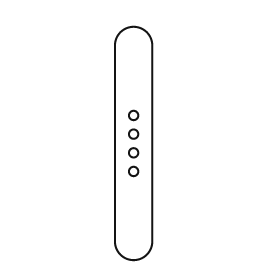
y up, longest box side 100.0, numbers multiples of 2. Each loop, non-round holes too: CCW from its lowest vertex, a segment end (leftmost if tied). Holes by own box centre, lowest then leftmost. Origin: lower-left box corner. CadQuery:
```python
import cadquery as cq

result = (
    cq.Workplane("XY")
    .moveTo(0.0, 8.0)
    .threePointArc((8.0, 0.0), (16.0, 8.0))
    .lineTo(16.0, 92.0)
    .threePointArc((8.0, 100.0), (0.0, 92.0))
    .close()
    .moveTo(8.0, 38.0)
    .circle(2.0)
    .moveTo(8.0, 46.0)
    .circle(2.0)
    .moveTo(8.0, 54.0)
    .circle(2.0)
    .moveTo(8.0, 62.0)
    .circle(2.0)
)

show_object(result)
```